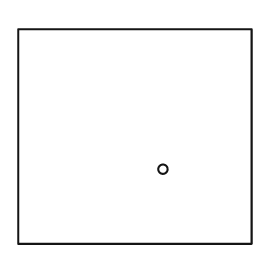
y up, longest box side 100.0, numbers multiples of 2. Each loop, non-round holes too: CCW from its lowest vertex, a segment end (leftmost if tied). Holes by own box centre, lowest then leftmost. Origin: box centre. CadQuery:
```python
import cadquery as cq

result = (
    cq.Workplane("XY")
    .moveTo(-50.0, -46.0)
    .lineTo(50.0, -46.0)
    .lineTo(50.0, 46.0)
    .lineTo(-50.0, 46.0)
    .close()
    .moveTo(12.0, -14.0)
    .circle(2.0)
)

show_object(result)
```